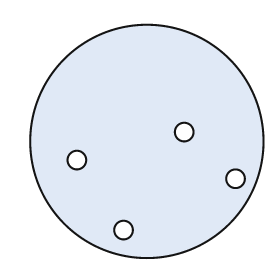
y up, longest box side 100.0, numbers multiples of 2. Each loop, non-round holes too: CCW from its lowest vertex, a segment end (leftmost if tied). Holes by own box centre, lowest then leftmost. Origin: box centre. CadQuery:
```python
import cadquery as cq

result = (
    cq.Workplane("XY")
    .moveTo(0.0, 0.0)
    .circle(50.0)
    .moveTo(-10.0, -38.0)
    .circle(4.0)
    .moveTo(38.0, -16.0)
    .circle(4.0)
    .moveTo(-30.0, -8.0)
    .circle(4.0)
    .moveTo(16.0, 4.0)
    .circle(4.0)
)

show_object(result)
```